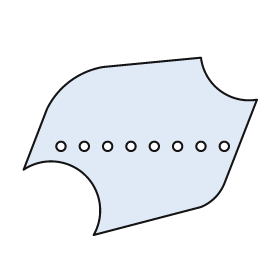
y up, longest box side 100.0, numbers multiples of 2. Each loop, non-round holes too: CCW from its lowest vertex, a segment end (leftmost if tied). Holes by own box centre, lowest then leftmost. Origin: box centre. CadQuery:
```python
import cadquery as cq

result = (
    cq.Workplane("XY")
    .moveTo(-20.0, -38.0)
    .lineTo(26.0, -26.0)
    .threePointArc((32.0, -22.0), (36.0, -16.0))
    .lineTo(50.0, 20.0)
    .threePointArc((34.0, 24.0), (26.0, 38.0))
    .lineTo(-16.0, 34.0)
    .threePointArc((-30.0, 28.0), (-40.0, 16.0))
    .lineTo(-50.0, -10.0)
    .threePointArc((-24.0, -12.0), (-20.0, -38.0))
    .close()
    .moveTo(-34.0, 0.0)
    .circle(2.0)
    .moveTo(-24.0, 0.0)
    .circle(2.0)
    .moveTo(-14.0, 0.0)
    .circle(2.0)
    .moveTo(-4.0, 0.0)
    .circle(2.0)
    .moveTo(6.0, 0.0)
    .circle(2.0)
    .moveTo(16.0, 0.0)
    .circle(2.0)
    .moveTo(26.0, 0.0)
    .circle(2.0)
    .moveTo(36.0, 0.0)
    .circle(2.0)
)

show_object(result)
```